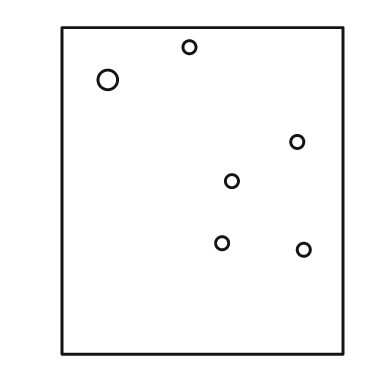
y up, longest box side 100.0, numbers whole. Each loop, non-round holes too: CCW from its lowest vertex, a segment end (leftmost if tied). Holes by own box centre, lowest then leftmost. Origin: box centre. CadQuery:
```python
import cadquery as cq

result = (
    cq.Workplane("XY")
    .moveTo(-43.0, -50.0)
    .lineTo(43.0, -50.0)
    .lineTo(43.0, 50.0)
    .lineTo(-43.0, 50.0)
    .close()
    .moveTo(31.0, -18.0)
    .circle(2.0)
    .moveTo(6.0, -16.0)
    .circle(2.0)
    .moveTo(9.0, 3.0)
    .circle(2.0)
    .moveTo(29.0, 15.0)
    .circle(2.0)
    .moveTo(-29.0, 34.0)
    .circle(3.0)
    .moveTo(-4.0, 44.0)
    .circle(2.0)
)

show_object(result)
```